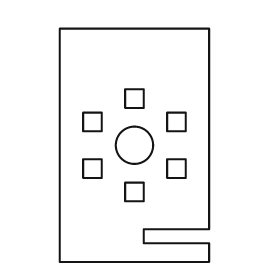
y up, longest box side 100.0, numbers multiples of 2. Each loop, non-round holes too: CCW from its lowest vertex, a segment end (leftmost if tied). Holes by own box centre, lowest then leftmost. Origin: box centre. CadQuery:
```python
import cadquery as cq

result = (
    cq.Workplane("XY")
    .moveTo(-32.0, -50.0)
    .lineTo(32.0, -50.0)
    .lineTo(32.0, -42.0)
    .lineTo(4.0, -42.0)
    .lineTo(4.0, -36.0)
    .lineTo(32.0, -36.0)
    .lineTo(32.0, 50.0)
    .lineTo(-32.0, 50.0)
    .close()
    .moveTo(-4.0, -24.0)
    .lineTo(4.0, -24.0)
    .lineTo(4.0, -16.0)
    .lineTo(-4.0, -16.0)
    .close()
    .moveTo(-22.0, -14.0)
    .lineTo(-14.0, -14.0)
    .lineTo(-14.0, -6.0)
    .lineTo(-22.0, -6.0)
    .close()
    .moveTo(14.0, -14.0)
    .lineTo(22.0, -14.0)
    .lineTo(22.0, -6.0)
    .lineTo(14.0, -6.0)
    .close()
    .moveTo(0.0, 0.0)
    .circle(8.0)
    .moveTo(-22.0, 6.0)
    .lineTo(-14.0, 6.0)
    .lineTo(-14.0, 14.0)
    .lineTo(-22.0, 14.0)
    .close()
    .moveTo(14.0, 6.0)
    .lineTo(22.0, 6.0)
    .lineTo(22.0, 14.0)
    .lineTo(14.0, 14.0)
    .close()
    .moveTo(-4.0, 16.0)
    .lineTo(4.0, 16.0)
    .lineTo(4.0, 24.0)
    .lineTo(-4.0, 24.0)
    .close()
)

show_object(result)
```